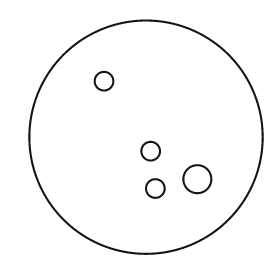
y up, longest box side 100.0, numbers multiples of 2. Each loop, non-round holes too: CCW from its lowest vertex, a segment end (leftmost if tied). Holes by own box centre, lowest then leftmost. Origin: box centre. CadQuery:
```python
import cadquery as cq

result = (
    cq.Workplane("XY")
    .moveTo(0.0, 0.0)
    .circle(50.0)
    .moveTo(4.0, -22.0)
    .circle(4.0)
    .moveTo(22.0, -18.0)
    .circle(6.0)
    .moveTo(2.0, -6.0)
    .circle(4.0)
    .moveTo(-18.0, 24.0)
    .circle(4.0)
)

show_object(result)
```